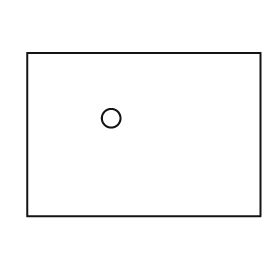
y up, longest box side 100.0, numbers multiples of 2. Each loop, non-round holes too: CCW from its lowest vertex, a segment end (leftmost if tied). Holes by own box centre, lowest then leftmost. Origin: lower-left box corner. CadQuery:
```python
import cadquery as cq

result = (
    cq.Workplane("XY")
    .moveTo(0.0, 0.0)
    .lineTo(100.0, 0.0)
    .lineTo(100.0, 70.0)
    .lineTo(0.0, 70.0)
    .close()
    .moveTo(36.0, 42.0)
    .circle(4.0)
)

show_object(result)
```